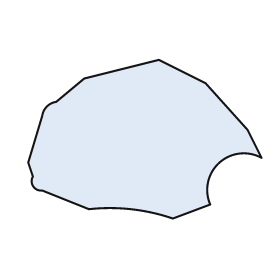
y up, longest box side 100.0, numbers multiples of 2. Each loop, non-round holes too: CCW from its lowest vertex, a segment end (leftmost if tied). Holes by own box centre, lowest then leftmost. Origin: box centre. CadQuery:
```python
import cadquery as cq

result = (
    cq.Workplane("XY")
    .moveTo(12.0, -34.0)
    .lineTo(28.0, -28.0)
    .threePointArc((32.0, -10.0), (50.0, -8.0))
    .lineTo(44.0, 4.0)
    .lineTo(26.0, 24.0)
    .lineTo(6.0, 34.0)
    .lineTo(-26.0, 26.0)
    .lineTo(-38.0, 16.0)
    .threePointArc((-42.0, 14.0), (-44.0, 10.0))
    .lineTo(-50.0, -10.0)
    .lineTo(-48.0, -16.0)
    .threePointArc((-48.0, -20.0), (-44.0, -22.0))
    .lineTo(-24.0, -30.0)
    .threePointArc((-6.0, -30.0), (12.0, -34.0))
    .close()
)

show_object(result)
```